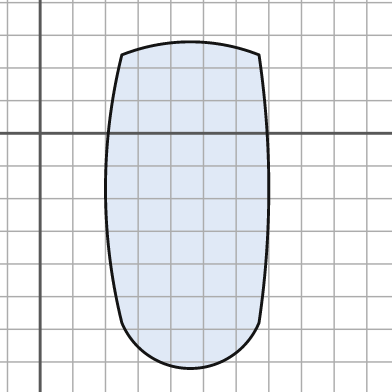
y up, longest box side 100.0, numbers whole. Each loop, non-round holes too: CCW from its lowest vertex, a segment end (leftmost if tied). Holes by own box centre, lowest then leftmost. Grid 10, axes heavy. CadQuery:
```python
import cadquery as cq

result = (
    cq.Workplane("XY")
    .moveTo(25.0, -58.0)
    .threePointArc((46.0, -72.0), (67.0, -58.0))
    .threePointArc((70.0, -17.0), (67.0, 24.0))
    .threePointArc((46.0, 28.0), (25.0, 24.0))
    .threePointArc((20.0, -17.0), (25.0, -58.0))
    .close()
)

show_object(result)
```